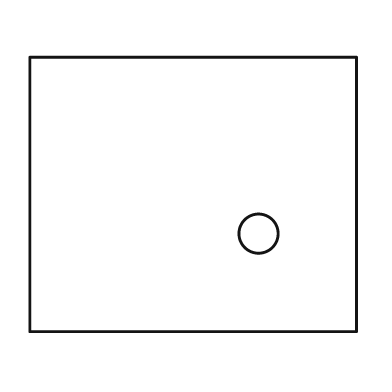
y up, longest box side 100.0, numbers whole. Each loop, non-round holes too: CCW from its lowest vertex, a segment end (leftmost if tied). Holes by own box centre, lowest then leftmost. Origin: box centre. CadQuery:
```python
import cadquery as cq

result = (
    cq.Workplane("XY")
    .moveTo(-50.0, -42.0)
    .lineTo(50.0, -42.0)
    .lineTo(50.0, 42.0)
    .lineTo(-50.0, 42.0)
    .close()
    .moveTo(20.0, -12.0)
    .circle(6.0)
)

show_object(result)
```